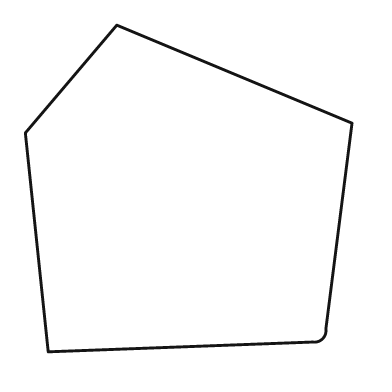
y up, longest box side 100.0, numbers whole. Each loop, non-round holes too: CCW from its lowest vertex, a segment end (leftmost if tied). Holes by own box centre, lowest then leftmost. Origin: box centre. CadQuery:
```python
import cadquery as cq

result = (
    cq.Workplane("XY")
    .moveTo(-43.0, -50.0)
    .lineTo(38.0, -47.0)
    .threePointArc((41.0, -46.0), (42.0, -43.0))
    .lineTo(50.0, 20.0)
    .lineTo(-22.0, 50.0)
    .lineTo(-50.0, 17.0)
    .close()
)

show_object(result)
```